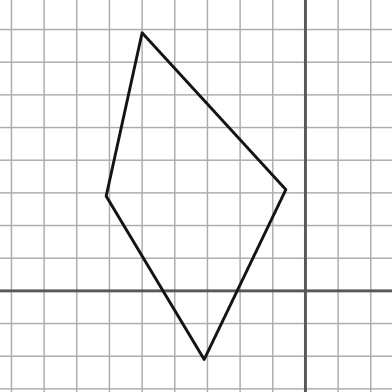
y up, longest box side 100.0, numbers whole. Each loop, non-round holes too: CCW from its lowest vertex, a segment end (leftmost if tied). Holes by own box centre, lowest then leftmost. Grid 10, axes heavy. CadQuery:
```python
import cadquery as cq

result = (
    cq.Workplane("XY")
    .moveTo(-31.0, -21.0)
    .lineTo(-6.0, 31.0)
    .lineTo(-50.0, 79.0)
    .lineTo(-61.0, 29.0)
    .close()
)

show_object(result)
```